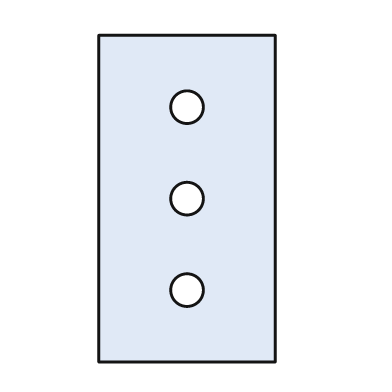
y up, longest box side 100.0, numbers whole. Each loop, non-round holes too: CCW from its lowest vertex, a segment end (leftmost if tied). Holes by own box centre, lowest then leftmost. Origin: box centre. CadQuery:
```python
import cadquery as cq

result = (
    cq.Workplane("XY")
    .moveTo(-27.0, -50.0)
    .lineTo(27.0, -50.0)
    .lineTo(27.0, 50.0)
    .lineTo(-27.0, 50.0)
    .close()
    .moveTo(0.0, -28.0)
    .circle(5.0)
    .moveTo(0.0, 0.0)
    .circle(5.0)
    .moveTo(0.0, 28.0)
    .circle(5.0)
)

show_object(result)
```